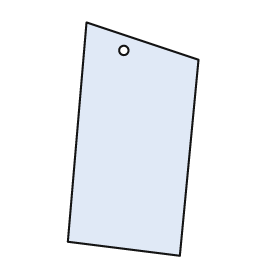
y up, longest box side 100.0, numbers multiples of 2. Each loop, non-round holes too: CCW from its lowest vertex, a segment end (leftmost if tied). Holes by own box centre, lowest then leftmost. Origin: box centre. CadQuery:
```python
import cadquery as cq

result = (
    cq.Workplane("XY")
    .moveTo(20.0, -50.0)
    .lineTo(28.0, 34.0)
    .lineTo(-20.0, 50.0)
    .lineTo(-28.0, -44.0)
    .close()
    .moveTo(-4.0, 38.0)
    .circle(2.0)
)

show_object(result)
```